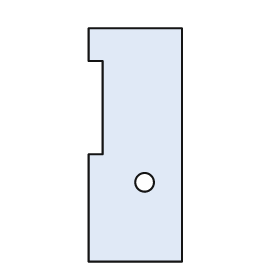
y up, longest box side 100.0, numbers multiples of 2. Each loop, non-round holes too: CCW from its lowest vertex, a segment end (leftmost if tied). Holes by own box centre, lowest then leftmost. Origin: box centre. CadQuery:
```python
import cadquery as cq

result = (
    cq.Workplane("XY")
    .moveTo(-20.0, -50.0)
    .lineTo(20.0, -50.0)
    .lineTo(20.0, 50.0)
    .lineTo(-20.0, 50.0)
    .lineTo(-20.0, 36.0)
    .lineTo(-14.0, 36.0)
    .lineTo(-14.0, -4.0)
    .lineTo(-20.0, -4.0)
    .close()
    .moveTo(4.0, -16.0)
    .circle(4.0)
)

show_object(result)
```